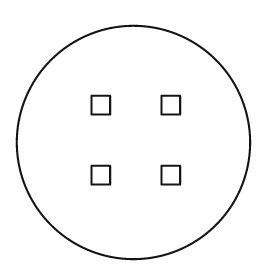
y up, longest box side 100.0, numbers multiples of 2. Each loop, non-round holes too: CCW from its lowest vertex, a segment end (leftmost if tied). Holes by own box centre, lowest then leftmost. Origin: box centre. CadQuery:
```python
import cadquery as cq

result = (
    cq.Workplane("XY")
    .moveTo(0.0, 0.0)
    .circle(50.0)
    .moveTo(-18.0, -18.0)
    .lineTo(-10.0, -18.0)
    .lineTo(-10.0, -10.0)
    .lineTo(-18.0, -10.0)
    .close()
    .moveTo(12.0, -18.0)
    .lineTo(20.0, -18.0)
    .lineTo(20.0, -10.0)
    .lineTo(12.0, -10.0)
    .close()
    .moveTo(-18.0, 12.0)
    .lineTo(-10.0, 12.0)
    .lineTo(-10.0, 20.0)
    .lineTo(-18.0, 20.0)
    .close()
    .moveTo(12.0, 12.0)
    .lineTo(20.0, 12.0)
    .lineTo(20.0, 20.0)
    .lineTo(12.0, 20.0)
    .close()
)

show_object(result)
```